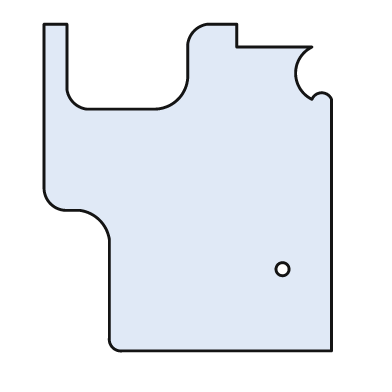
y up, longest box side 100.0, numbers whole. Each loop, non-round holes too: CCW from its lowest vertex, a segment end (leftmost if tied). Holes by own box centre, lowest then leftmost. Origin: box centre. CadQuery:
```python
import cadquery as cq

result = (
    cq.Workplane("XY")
    .moveTo(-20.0, -50.0)
    .lineTo(44.0, -50.0)
    .lineTo(44.0, 27.0)
    .threePointArc((41.0, 29.0), (38.0, 27.0))
    .threePointArc((33.0, 35.0), (38.0, 43.0))
    .lineTo(15.0, 43.0)
    .lineTo(15.0, 50.0)
    .lineTo(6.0, 50.0)
    .threePointArc((2.0, 48.0), (0.0, 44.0))
    .lineTo(0.0, 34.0)
    .threePointArc((-3.0, 27.0), (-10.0, 24.0))
    .lineTo(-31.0, 24.0)
    .threePointArc((-35.0, 26.0), (-37.0, 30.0))
    .lineTo(-37.0, 50.0)
    .lineTo(-44.0, 50.0)
    .lineTo(-44.0, 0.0)
    .threePointArc((-42.0, -5.0), (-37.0, -7.0))
    .lineTo(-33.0, -7.0)
    .threePointArc((-27.0, -10.0), (-24.0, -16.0))
    .lineTo(-24.0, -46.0)
    .threePointArc((-23.0, -49.0), (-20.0, -50.0))
    .close()
    .moveTo(29.0, -25.0)
    .circle(2.0)
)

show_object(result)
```